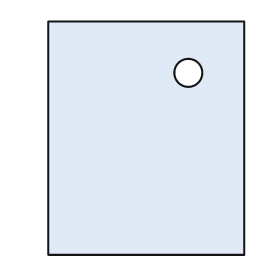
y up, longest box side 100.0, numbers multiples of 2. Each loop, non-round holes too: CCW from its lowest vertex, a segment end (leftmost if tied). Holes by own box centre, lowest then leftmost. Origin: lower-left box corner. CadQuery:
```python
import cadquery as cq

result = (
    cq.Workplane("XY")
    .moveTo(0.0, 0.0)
    .lineTo(84.0, 0.0)
    .lineTo(84.0, 100.0)
    .lineTo(0.0, 100.0)
    .close()
    .moveTo(60.0, 78.0)
    .circle(6.0)
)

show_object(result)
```